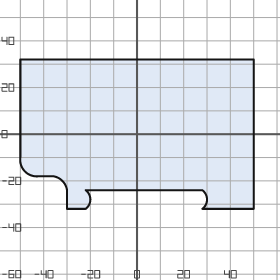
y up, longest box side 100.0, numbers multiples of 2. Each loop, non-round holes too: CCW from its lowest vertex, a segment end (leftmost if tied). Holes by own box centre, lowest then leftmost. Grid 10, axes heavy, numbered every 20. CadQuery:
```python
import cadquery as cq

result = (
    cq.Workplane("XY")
    .moveTo(-30.0, -32.0)
    .lineTo(-22.0, -32.0)
    .threePointArc((-20.0, -28.0), (-22.0, -24.0))
    .lineTo(28.0, -24.0)
    .threePointArc((30.0, -28.0), (28.0, -32.0))
    .lineTo(50.0, -32.0)
    .lineTo(50.0, 32.0)
    .lineTo(-50.0, 32.0)
    .lineTo(-50.0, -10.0)
    .threePointArc((-48.0, -16.0), (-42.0, -18.0))
    .lineTo(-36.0, -18.0)
    .threePointArc((-32.0, -20.0), (-30.0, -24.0))
    .close()
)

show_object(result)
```